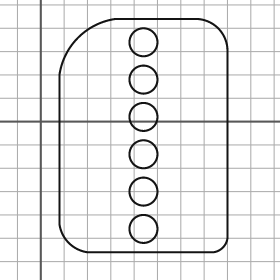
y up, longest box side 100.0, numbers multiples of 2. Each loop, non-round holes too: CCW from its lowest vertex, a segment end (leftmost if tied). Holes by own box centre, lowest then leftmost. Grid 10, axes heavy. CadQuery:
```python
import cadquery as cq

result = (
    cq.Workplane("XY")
    .moveTo(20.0, -56.0)
    .lineTo(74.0, -56.0)
    .threePointArc((78.0, -54.0), (80.0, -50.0))
    .lineTo(80.0, 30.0)
    .threePointArc((76.0, 40.0), (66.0, 44.0))
    .lineTo(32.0, 44.0)
    .threePointArc((16.0, 36.0), (8.0, 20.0))
    .lineTo(8.0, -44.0)
    .threePointArc((12.0, -52.0), (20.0, -56.0))
    .close()
    .moveTo(44.0, -46.0)
    .circle(6.0)
    .moveTo(44.0, -30.0)
    .circle(6.0)
    .moveTo(44.0, -14.0)
    .circle(6.0)
    .moveTo(44.0, 2.0)
    .circle(6.0)
    .moveTo(44.0, 18.0)
    .circle(6.0)
    .moveTo(44.0, 34.0)
    .circle(6.0)
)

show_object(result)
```